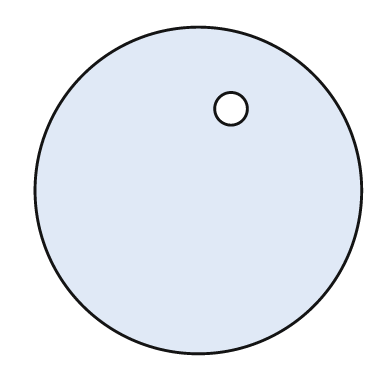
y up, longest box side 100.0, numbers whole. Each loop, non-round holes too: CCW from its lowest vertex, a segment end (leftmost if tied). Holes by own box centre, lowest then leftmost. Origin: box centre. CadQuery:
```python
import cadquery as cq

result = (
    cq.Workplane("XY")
    .moveTo(0.0, 0.0)
    .circle(50.0)
    .moveTo(10.0, 25.0)
    .circle(5.0)
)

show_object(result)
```